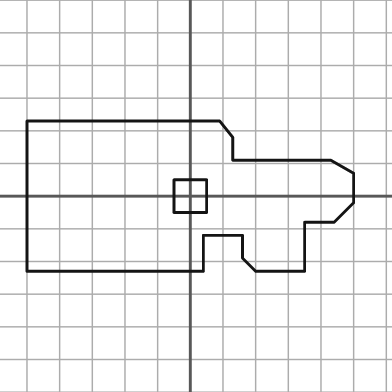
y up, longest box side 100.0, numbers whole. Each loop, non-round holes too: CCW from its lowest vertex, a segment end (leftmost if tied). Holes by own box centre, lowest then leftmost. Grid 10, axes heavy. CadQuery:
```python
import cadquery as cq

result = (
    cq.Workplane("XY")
    .moveTo(-50.0, -23.0)
    .lineTo(4.0, -23.0)
    .lineTo(4.0, -12.0)
    .lineTo(16.0, -12.0)
    .lineTo(16.0, -19.0)
    .lineTo(20.0, -23.0)
    .lineTo(35.0, -23.0)
    .lineTo(35.0, -8.0)
    .lineTo(44.0, -8.0)
    .lineTo(50.0, -2.0)
    .lineTo(50.0, 7.0)
    .lineTo(43.0, 11.0)
    .lineTo(13.0, 11.0)
    .lineTo(13.0, 18.0)
    .lineTo(9.0, 23.0)
    .lineTo(-50.0, 23.0)
    .close()
    .moveTo(-5.0, -5.0)
    .lineTo(5.0, -5.0)
    .lineTo(5.0, 5.0)
    .lineTo(-5.0, 5.0)
    .close()
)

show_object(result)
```